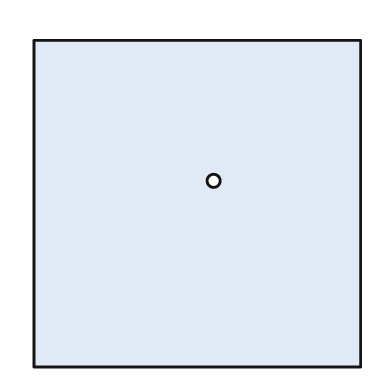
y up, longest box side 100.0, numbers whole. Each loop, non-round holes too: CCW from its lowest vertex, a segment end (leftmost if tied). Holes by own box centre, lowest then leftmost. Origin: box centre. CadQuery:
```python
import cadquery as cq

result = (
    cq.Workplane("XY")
    .moveTo(-50.0, -50.0)
    .lineTo(50.0, -50.0)
    .lineTo(50.0, 50.0)
    .lineTo(-50.0, 50.0)
    .close()
    .moveTo(5.0, 7.0)
    .circle(2.0)
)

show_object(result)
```